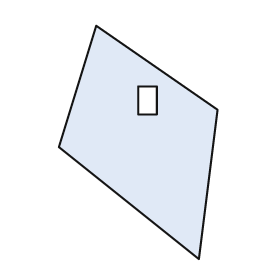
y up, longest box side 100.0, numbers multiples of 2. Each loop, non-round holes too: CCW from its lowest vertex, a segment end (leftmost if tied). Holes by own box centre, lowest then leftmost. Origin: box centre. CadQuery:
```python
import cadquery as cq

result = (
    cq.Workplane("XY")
    .moveTo(26.0, -50.0)
    .lineTo(34.0, 14.0)
    .lineTo(-18.0, 50.0)
    .lineTo(-34.0, -2.0)
    .close()
    .moveTo(0.0, 12.0)
    .lineTo(8.0, 12.0)
    .lineTo(8.0, 24.0)
    .lineTo(0.0, 24.0)
    .close()
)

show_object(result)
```